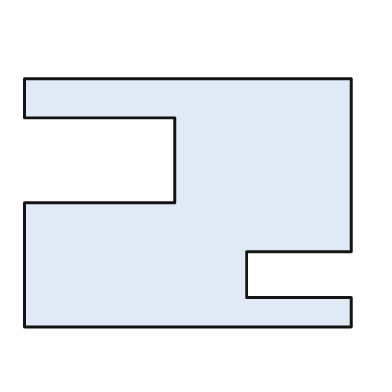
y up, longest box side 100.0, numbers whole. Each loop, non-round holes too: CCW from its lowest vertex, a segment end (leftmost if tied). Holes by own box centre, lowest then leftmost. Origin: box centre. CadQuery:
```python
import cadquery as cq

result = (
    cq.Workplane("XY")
    .moveTo(-50.0, -38.0)
    .lineTo(50.0, -38.0)
    .lineTo(50.0, -29.0)
    .lineTo(18.0, -29.0)
    .lineTo(18.0, -15.0)
    .lineTo(50.0, -15.0)
    .lineTo(50.0, 38.0)
    .lineTo(-50.0, 38.0)
    .lineTo(-50.0, 26.0)
    .lineTo(-4.0, 26.0)
    .lineTo(-4.0, 0.0)
    .lineTo(-50.0, 0.0)
    .close()
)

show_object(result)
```